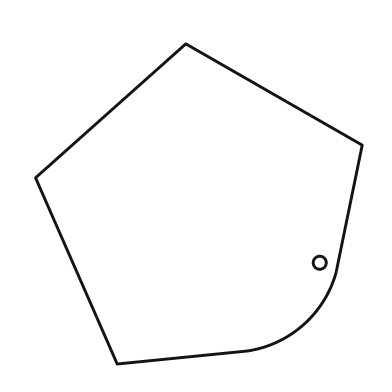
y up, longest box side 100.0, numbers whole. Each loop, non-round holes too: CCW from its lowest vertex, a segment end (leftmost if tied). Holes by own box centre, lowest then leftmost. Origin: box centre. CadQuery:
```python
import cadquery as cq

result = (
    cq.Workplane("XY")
    .moveTo(-25.0, -49.0)
    .lineTo(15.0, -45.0)
    .threePointArc((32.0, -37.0), (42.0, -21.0))
    .lineTo(50.0, 18.0)
    .lineTo(-4.0, 49.0)
    .lineTo(-50.0, 8.0)
    .close()
    .moveTo(37.0, -18.0)
    .circle(2.0)
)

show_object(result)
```